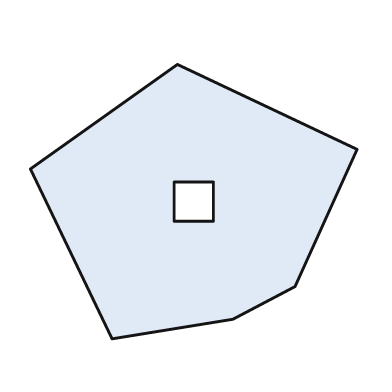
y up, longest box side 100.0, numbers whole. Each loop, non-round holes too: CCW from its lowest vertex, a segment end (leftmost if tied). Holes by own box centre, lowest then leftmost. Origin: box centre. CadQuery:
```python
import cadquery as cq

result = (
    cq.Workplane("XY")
    .moveTo(-25.0, -42.0)
    .lineTo(12.0, -36.0)
    .lineTo(31.0, -26.0)
    .lineTo(50.0, 16.0)
    .lineTo(-5.0, 42.0)
    .lineTo(-50.0, 10.0)
    .close()
    .moveTo(-6.0, -6.0)
    .lineTo(6.0, -6.0)
    .lineTo(6.0, 6.0)
    .lineTo(-6.0, 6.0)
    .close()
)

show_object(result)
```